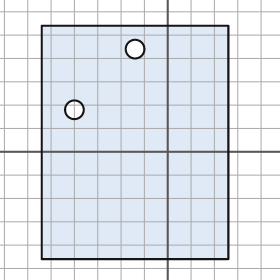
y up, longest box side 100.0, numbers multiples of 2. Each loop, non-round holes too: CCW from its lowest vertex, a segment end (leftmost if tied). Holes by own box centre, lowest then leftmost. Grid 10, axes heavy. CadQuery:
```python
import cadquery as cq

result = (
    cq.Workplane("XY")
    .moveTo(-54.0, -46.0)
    .lineTo(26.0, -46.0)
    .lineTo(26.0, 54.0)
    .lineTo(-54.0, 54.0)
    .close()
    .moveTo(-40.0, 18.0)
    .circle(4.0)
    .moveTo(-14.0, 44.0)
    .circle(4.0)
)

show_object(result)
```